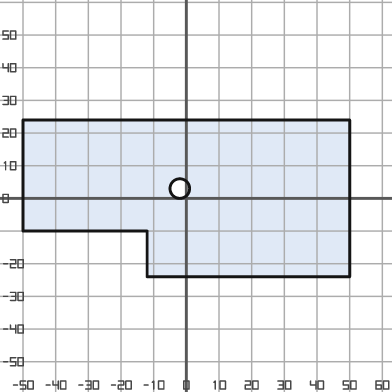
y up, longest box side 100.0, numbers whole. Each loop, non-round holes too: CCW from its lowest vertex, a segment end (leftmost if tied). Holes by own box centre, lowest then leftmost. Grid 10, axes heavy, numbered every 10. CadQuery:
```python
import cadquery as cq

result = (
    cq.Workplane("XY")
    .moveTo(-12.0, -24.0)
    .lineTo(50.0, -24.0)
    .lineTo(50.0, 24.0)
    .lineTo(-50.0, 24.0)
    .lineTo(-50.0, -10.0)
    .lineTo(-12.0, -10.0)
    .close()
    .moveTo(-2.0, 3.0)
    .circle(3.0)
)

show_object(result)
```